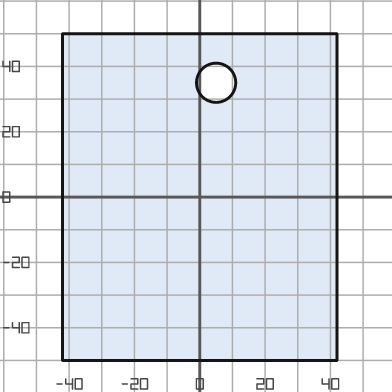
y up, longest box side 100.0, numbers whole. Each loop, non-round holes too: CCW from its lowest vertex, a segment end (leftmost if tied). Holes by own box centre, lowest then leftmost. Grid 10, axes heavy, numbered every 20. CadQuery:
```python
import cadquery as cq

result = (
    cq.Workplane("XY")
    .moveTo(-42.0, -50.0)
    .lineTo(42.0, -50.0)
    .lineTo(42.0, 50.0)
    .lineTo(-42.0, 50.0)
    .close()
    .moveTo(5.0, 35.0)
    .circle(6.0)
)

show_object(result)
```